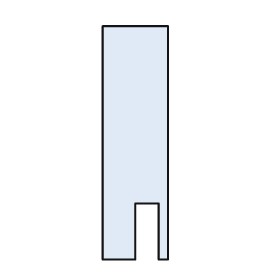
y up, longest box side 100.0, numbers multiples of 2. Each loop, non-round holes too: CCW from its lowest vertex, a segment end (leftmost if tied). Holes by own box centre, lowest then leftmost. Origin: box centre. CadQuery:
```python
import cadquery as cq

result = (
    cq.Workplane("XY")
    .moveTo(-14.0, -50.0)
    .lineTo(0.0, -50.0)
    .lineTo(0.0, -26.0)
    .lineTo(10.0, -26.0)
    .lineTo(10.0, -50.0)
    .lineTo(14.0, -50.0)
    .lineTo(14.0, 50.0)
    .lineTo(-14.0, 50.0)
    .close()
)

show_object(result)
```